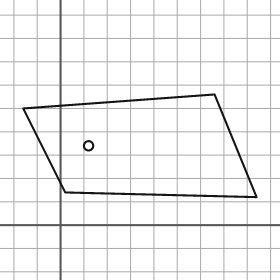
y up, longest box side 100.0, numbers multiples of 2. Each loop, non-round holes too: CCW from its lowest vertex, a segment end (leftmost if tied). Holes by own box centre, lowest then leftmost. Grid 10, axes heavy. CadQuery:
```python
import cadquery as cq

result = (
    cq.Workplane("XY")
    .moveTo(84.0, 12.0)
    .lineTo(66.0, 56.0)
    .lineTo(-16.0, 50.0)
    .lineTo(2.0, 14.0)
    .close()
    .moveTo(12.0, 34.0)
    .circle(2.0)
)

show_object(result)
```